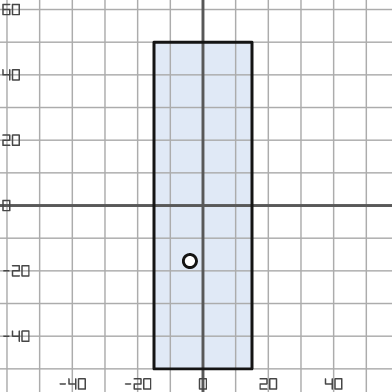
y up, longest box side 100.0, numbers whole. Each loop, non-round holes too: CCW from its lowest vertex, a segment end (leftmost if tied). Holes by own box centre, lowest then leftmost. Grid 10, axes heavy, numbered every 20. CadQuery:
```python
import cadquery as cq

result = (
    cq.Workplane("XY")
    .moveTo(-15.0, -50.0)
    .lineTo(15.0, -50.0)
    .lineTo(15.0, 50.0)
    .lineTo(-15.0, 50.0)
    .close()
    .moveTo(-4.0, -17.0)
    .circle(2.0)
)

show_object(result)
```